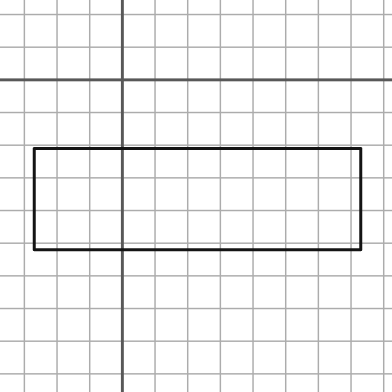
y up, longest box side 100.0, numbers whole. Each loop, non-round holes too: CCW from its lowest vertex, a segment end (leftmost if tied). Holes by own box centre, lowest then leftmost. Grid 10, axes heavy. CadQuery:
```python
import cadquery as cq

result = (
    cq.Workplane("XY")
    .moveTo(-27.0, -52.0)
    .lineTo(73.0, -52.0)
    .lineTo(73.0, -21.0)
    .lineTo(-27.0, -21.0)
    .close()
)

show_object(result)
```